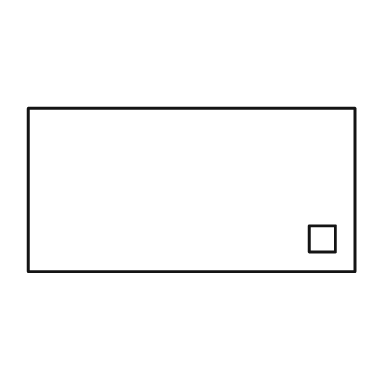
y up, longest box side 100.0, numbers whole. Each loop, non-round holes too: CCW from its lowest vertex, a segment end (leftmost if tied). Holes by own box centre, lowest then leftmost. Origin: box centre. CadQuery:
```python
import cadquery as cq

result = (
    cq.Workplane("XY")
    .moveTo(-50.0, -25.0)
    .lineTo(50.0, -25.0)
    .lineTo(50.0, 25.0)
    .lineTo(-50.0, 25.0)
    .close()
    .moveTo(36.0, -19.0)
    .lineTo(44.0, -19.0)
    .lineTo(44.0, -11.0)
    .lineTo(36.0, -11.0)
    .close()
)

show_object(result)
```